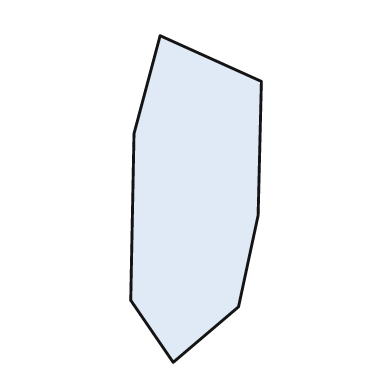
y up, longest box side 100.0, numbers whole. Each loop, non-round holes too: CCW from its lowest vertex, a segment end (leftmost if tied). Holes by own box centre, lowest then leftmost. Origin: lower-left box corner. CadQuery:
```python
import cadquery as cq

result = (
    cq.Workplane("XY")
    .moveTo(13.0, 0.0)
    .lineTo(33.0, 17.0)
    .lineTo(39.0, 45.0)
    .lineTo(40.0, 86.0)
    .lineTo(9.0, 100.0)
    .lineTo(1.0, 70.0)
    .lineTo(0.0, 19.0)
    .close()
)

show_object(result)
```